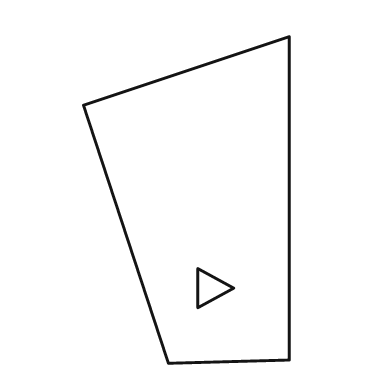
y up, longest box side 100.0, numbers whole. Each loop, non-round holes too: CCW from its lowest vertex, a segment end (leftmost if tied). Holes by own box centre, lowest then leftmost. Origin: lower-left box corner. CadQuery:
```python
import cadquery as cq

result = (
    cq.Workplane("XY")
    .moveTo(26.0, 0.0)
    .lineTo(63.0, 1.0)
    .lineTo(63.0, 100.0)
    .lineTo(0.0, 79.0)
    .close()
    .moveTo(35.0, 17.0)
    .lineTo(46.0, 23.0)
    .lineTo(35.0, 29.0)
    .close()
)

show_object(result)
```